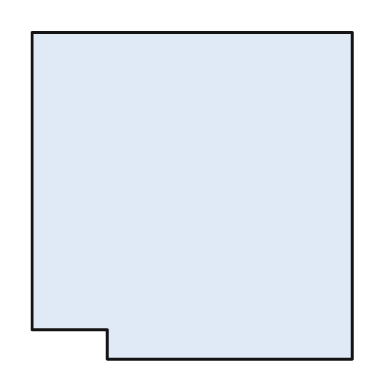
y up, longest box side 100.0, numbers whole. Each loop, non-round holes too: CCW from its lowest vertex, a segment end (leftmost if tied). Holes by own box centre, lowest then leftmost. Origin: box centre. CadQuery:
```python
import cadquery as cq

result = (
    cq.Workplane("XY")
    .moveTo(-26.0, -50.0)
    .lineTo(49.0, -50.0)
    .lineTo(49.0, 50.0)
    .lineTo(-49.0, 50.0)
    .lineTo(-49.0, -41.0)
    .lineTo(-26.0, -41.0)
    .close()
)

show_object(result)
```